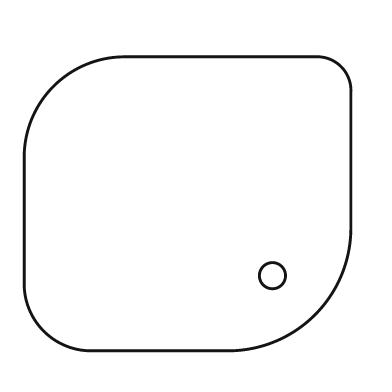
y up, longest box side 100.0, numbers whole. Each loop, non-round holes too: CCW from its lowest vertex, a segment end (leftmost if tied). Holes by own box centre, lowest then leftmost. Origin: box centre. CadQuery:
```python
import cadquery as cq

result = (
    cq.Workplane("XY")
    .moveTo(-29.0, -45.0)
    .lineTo(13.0, -45.0)
    .threePointArc((39.0, -34.0), (50.0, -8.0))
    .lineTo(50.0, 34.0)
    .threePointArc((47.0, 42.0), (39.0, 45.0))
    .lineTo(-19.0, 45.0)
    .threePointArc((-41.0, 36.0), (-50.0, 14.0))
    .lineTo(-50.0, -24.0)
    .threePointArc((-44.0, -39.0), (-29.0, -45.0))
    .close()
    .moveTo(26.0, -22.0)
    .circle(4.0)
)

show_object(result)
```